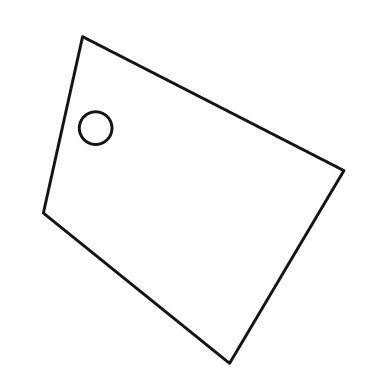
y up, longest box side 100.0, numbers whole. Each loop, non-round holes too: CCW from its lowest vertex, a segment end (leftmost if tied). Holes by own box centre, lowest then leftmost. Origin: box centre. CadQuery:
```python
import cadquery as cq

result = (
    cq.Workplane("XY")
    .moveTo(11.0, -50.0)
    .lineTo(46.0, 9.0)
    .lineTo(-34.0, 50.0)
    .lineTo(-46.0, -4.0)
    .close()
    .moveTo(-30.0, 22.0)
    .circle(5.0)
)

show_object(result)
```